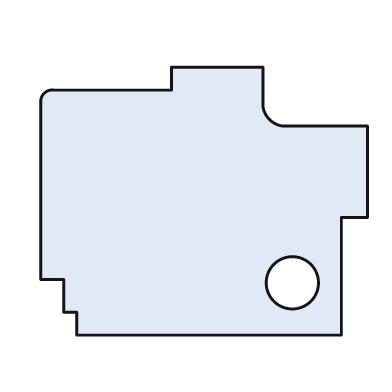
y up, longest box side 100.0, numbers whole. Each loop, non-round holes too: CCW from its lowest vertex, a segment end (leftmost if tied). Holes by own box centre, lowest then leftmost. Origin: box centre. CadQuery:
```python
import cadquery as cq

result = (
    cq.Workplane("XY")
    .moveTo(-39.0, -41.0)
    .lineTo(42.0, -41.0)
    .lineTo(42.0, -5.0)
    .lineTo(50.0, -5.0)
    .lineTo(50.0, 23.0)
    .lineTo(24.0, 23.0)
    .threePointArc((20.0, 25.0), (18.0, 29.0))
    .lineTo(18.0, 41.0)
    .lineTo(-10.0, 41.0)
    .lineTo(-10.0, 34.0)
    .lineTo(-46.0, 34.0)
    .threePointArc((-49.0, 33.0), (-50.0, 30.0))
    .lineTo(-50.0, -24.0)
    .lineTo(-43.0, -24.0)
    .lineTo(-43.0, -34.0)
    .lineTo(-39.0, -34.0)
    .close()
    .moveTo(27.0, -25.0)
    .circle(8.0)
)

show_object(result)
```